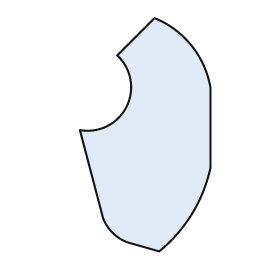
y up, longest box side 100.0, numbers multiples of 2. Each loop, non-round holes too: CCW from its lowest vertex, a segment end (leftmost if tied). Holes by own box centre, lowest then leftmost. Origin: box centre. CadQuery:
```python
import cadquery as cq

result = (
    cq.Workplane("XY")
    .moveTo(6.0, -50.0)
    .threePointArc((20.0, -34.0), (28.0, -14.0))
    .lineTo(28.0, 20.0)
    .threePointArc((20.0, 38.0), (4.0, 50.0))
    .lineTo(-12.0, 34.0)
    .threePointArc((-8.0, 12.0), (-28.0, 2.0))
    .lineTo(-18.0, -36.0)
    .threePointArc((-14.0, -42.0), (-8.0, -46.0))
    .close()
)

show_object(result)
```